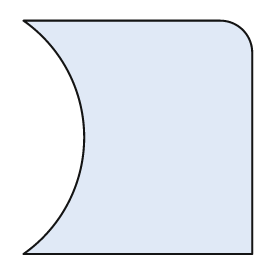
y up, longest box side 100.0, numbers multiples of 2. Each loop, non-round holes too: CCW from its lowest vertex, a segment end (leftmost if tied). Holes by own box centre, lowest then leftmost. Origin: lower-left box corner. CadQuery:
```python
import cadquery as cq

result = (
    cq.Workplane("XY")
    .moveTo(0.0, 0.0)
    .lineTo(98.0, 0.0)
    .lineTo(98.0, 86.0)
    .threePointArc((94.0, 96.0), (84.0, 100.0))
    .lineTo(0.0, 100.0)
    .threePointArc((26.0, 50.0), (0.0, 0.0))
    .close()
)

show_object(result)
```